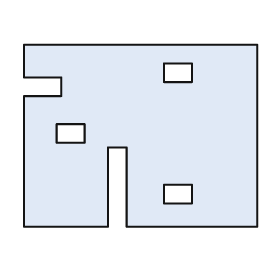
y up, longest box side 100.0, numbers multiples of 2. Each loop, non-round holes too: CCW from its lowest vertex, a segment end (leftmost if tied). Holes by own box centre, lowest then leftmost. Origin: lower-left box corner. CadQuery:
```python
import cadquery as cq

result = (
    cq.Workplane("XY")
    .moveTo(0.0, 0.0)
    .lineTo(36.0, 0.0)
    .lineTo(36.0, 34.0)
    .lineTo(44.0, 34.0)
    .lineTo(44.0, 0.0)
    .lineTo(100.0, 0.0)
    .lineTo(100.0, 78.0)
    .lineTo(0.0, 78.0)
    .lineTo(0.0, 64.0)
    .lineTo(16.0, 64.0)
    .lineTo(16.0, 56.0)
    .lineTo(0.0, 56.0)
    .close()
    .moveTo(60.0, 10.0)
    .lineTo(72.0, 10.0)
    .lineTo(72.0, 18.0)
    .lineTo(60.0, 18.0)
    .close()
    .moveTo(14.0, 36.0)
    .lineTo(26.0, 36.0)
    .lineTo(26.0, 44.0)
    .lineTo(14.0, 44.0)
    .close()
    .moveTo(60.0, 62.0)
    .lineTo(72.0, 62.0)
    .lineTo(72.0, 70.0)
    .lineTo(60.0, 70.0)
    .close()
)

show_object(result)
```